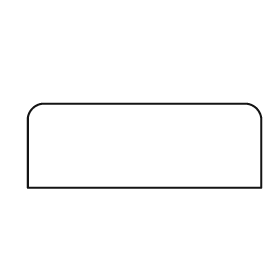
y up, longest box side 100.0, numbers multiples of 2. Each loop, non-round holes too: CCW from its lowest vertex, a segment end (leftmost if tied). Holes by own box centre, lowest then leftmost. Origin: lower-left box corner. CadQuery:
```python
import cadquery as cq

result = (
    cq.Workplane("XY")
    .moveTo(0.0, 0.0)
    .lineTo(100.0, 0.0)
    .lineTo(100.0, 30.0)
    .threePointArc((98.0, 34.0), (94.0, 36.0))
    .lineTo(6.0, 36.0)
    .threePointArc((2.0, 34.0), (0.0, 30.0))
    .close()
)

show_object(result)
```